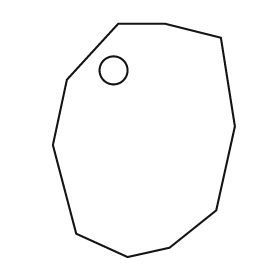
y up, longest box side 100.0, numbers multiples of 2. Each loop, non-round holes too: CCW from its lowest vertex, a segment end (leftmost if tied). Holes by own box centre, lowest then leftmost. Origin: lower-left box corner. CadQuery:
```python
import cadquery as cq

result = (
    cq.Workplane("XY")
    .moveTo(32.0, 0.0)
    .lineTo(50.0, 4.0)
    .lineTo(70.0, 20.0)
    .lineTo(78.0, 56.0)
    .lineTo(72.0, 94.0)
    .lineTo(48.0, 100.0)
    .lineTo(28.0, 100.0)
    .lineTo(6.0, 76.0)
    .lineTo(0.0, 48.0)
    .lineTo(10.0, 10.0)
    .close()
    .moveTo(26.0, 80.0)
    .circle(6.0)
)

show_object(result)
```